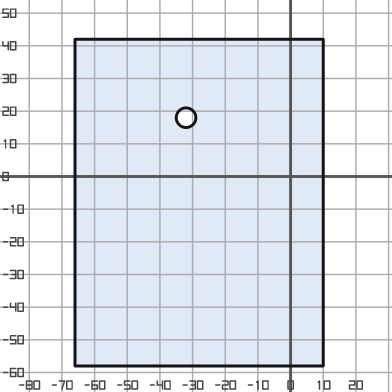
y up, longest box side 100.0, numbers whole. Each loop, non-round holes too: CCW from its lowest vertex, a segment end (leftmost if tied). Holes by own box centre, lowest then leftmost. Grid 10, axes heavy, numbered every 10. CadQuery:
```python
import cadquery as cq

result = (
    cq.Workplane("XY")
    .moveTo(-66.0, -58.0)
    .lineTo(10.0, -58.0)
    .lineTo(10.0, 42.0)
    .lineTo(-66.0, 42.0)
    .close()
    .moveTo(-32.0, 18.0)
    .circle(3.0)
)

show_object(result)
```